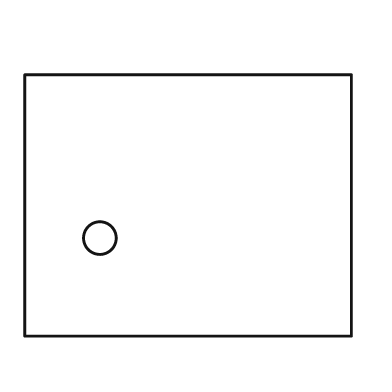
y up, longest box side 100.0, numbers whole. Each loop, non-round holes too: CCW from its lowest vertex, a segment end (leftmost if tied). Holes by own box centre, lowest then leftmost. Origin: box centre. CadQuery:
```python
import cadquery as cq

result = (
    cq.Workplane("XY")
    .moveTo(-50.0, -40.0)
    .lineTo(50.0, -40.0)
    .lineTo(50.0, 40.0)
    .lineTo(-50.0, 40.0)
    .close()
    .moveTo(-27.0, -10.0)
    .circle(5.0)
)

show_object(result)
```